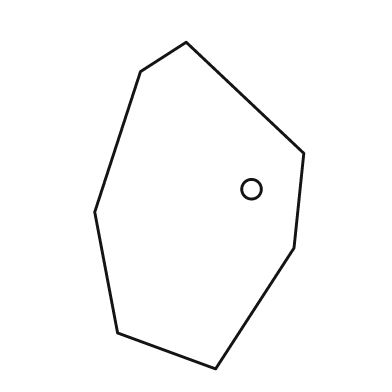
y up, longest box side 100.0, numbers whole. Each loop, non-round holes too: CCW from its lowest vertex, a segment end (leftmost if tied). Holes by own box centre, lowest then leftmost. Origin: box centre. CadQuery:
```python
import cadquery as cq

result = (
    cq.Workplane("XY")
    .moveTo(5.0, -50.0)
    .lineTo(29.0, -13.0)
    .lineTo(32.0, 16.0)
    .lineTo(-4.0, 50.0)
    .lineTo(-18.0, 41.0)
    .lineTo(-32.0, -2.0)
    .lineTo(-25.0, -39.0)
    .close()
    .moveTo(16.0, 5.0)
    .circle(3.0)
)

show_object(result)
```